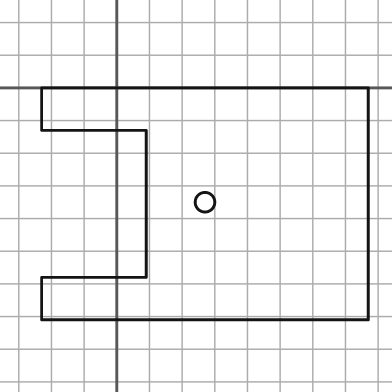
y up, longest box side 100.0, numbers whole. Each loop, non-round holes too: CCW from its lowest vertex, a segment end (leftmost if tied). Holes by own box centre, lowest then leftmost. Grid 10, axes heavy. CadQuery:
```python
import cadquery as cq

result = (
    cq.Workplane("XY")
    .moveTo(-23.0, -71.0)
    .lineTo(77.0, -71.0)
    .lineTo(77.0, 0.0)
    .lineTo(-23.0, 0.0)
    .lineTo(-23.0, -13.0)
    .lineTo(9.0, -13.0)
    .lineTo(9.0, -58.0)
    .lineTo(-23.0, -58.0)
    .close()
    .moveTo(27.0, -35.0)
    .circle(3.0)
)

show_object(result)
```